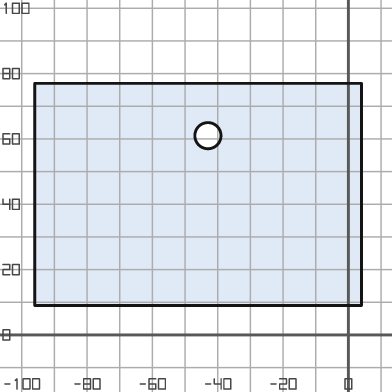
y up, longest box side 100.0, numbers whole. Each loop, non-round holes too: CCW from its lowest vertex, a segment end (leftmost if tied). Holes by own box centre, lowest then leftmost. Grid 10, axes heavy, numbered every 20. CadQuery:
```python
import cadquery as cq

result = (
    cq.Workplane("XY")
    .moveTo(-96.0, 9.0)
    .lineTo(4.0, 9.0)
    .lineTo(4.0, 77.0)
    .lineTo(-96.0, 77.0)
    .close()
    .moveTo(-43.0, 61.0)
    .circle(4.0)
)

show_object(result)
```